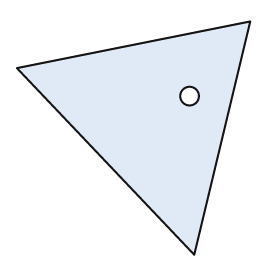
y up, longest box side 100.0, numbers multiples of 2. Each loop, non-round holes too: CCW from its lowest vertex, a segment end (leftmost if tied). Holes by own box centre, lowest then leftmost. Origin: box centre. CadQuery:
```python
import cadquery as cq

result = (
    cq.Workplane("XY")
    .moveTo(26.0, -50.0)
    .lineTo(50.0, 50.0)
    .lineTo(-50.0, 30.0)
    .close()
    .moveTo(24.0, 18.0)
    .circle(4.0)
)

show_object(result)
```